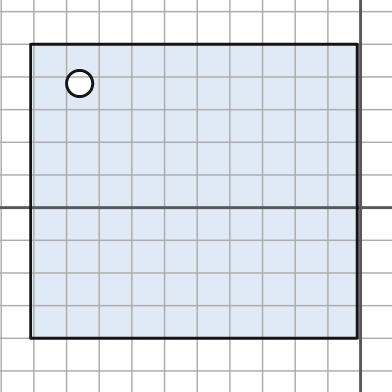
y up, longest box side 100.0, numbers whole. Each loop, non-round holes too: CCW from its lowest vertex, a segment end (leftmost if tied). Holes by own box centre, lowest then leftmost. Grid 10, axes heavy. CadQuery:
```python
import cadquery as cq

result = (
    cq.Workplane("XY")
    .moveTo(-101.0, -40.0)
    .lineTo(-1.0, -40.0)
    .lineTo(-1.0, 50.0)
    .lineTo(-101.0, 50.0)
    .close()
    .moveTo(-86.0, 38.0)
    .circle(4.0)
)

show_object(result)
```